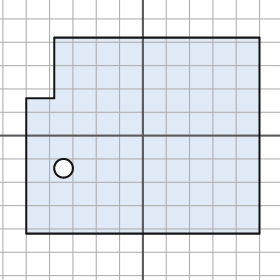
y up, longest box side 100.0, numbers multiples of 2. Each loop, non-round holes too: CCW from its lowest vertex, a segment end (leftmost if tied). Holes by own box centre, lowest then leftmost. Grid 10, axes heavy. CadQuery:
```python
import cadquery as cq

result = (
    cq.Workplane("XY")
    .moveTo(-50.0, -42.0)
    .lineTo(50.0, -42.0)
    .lineTo(50.0, 42.0)
    .lineTo(-38.0, 42.0)
    .lineTo(-38.0, 16.0)
    .lineTo(-50.0, 16.0)
    .close()
    .moveTo(-34.0, -14.0)
    .circle(4.0)
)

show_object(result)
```